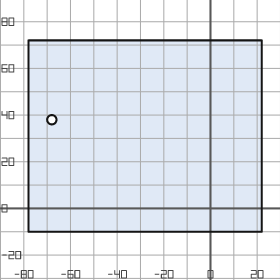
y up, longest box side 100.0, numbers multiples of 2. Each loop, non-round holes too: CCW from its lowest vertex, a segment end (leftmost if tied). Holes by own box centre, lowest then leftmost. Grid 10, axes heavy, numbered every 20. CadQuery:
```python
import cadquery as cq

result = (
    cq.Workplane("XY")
    .moveTo(-78.0, -10.0)
    .lineTo(22.0, -10.0)
    .lineTo(22.0, 72.0)
    .lineTo(-78.0, 72.0)
    .close()
    .moveTo(-68.0, 38.0)
    .circle(2.0)
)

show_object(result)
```